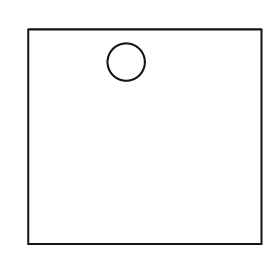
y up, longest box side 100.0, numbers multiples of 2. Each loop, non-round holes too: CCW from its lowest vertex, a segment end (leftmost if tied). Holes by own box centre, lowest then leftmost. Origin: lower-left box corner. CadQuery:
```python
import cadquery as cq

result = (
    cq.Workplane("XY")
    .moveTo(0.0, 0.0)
    .lineTo(100.0, 0.0)
    .lineTo(100.0, 92.0)
    .lineTo(0.0, 92.0)
    .close()
    .moveTo(42.0, 78.0)
    .circle(8.0)
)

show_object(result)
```